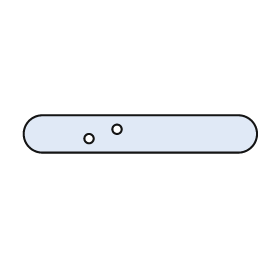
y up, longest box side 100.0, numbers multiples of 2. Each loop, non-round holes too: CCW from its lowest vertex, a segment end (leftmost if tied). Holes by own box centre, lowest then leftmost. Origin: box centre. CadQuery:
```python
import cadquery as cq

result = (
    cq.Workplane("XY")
    .moveTo(-42.0, -8.0)
    .lineTo(42.0, -8.0)
    .threePointArc((50.0, 0.0), (42.0, 8.0))
    .lineTo(-42.0, 8.0)
    .threePointArc((-50.0, 0.0), (-42.0, -8.0))
    .close()
    .moveTo(-22.0, -2.0)
    .circle(2.0)
    .moveTo(-10.0, 2.0)
    .circle(2.0)
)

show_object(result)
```